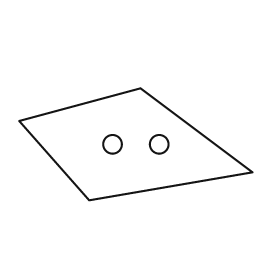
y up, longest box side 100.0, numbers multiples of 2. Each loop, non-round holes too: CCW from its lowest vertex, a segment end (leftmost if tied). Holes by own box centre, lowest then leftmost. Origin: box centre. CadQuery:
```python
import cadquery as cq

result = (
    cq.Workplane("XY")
    .moveTo(-20.0, -24.0)
    .lineTo(50.0, -12.0)
    .lineTo(2.0, 24.0)
    .lineTo(-50.0, 10.0)
    .close()
    .moveTo(-10.0, 0.0)
    .circle(4.0)
    .moveTo(10.0, 0.0)
    .circle(4.0)
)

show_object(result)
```